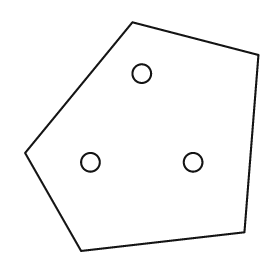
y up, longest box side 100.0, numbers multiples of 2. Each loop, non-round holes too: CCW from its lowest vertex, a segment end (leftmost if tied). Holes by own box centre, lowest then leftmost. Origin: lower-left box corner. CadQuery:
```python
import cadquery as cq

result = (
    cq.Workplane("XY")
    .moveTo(24.0, 0.0)
    .lineTo(94.0, 8.0)
    .lineTo(100.0, 84.0)
    .lineTo(46.0, 98.0)
    .lineTo(0.0, 42.0)
    .close()
    .moveTo(28.0, 38.0)
    .circle(4.0)
    .moveTo(72.0, 38.0)
    .circle(4.0)
    .moveTo(50.0, 76.0)
    .circle(4.0)
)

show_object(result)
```